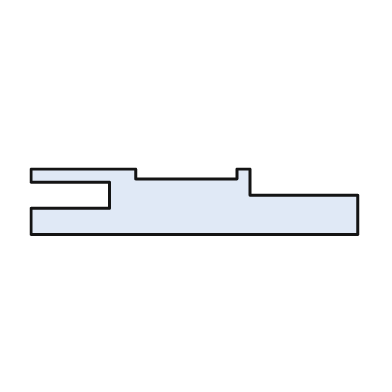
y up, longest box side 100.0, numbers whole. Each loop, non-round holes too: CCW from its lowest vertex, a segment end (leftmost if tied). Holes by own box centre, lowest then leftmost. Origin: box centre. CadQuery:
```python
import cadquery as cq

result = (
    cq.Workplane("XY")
    .moveTo(-50.0, -10.0)
    .lineTo(50.0, -10.0)
    .lineTo(50.0, 2.0)
    .lineTo(17.0, 2.0)
    .lineTo(17.0, 10.0)
    .lineTo(13.0, 10.0)
    .lineTo(13.0, 7.0)
    .lineTo(-18.0, 7.0)
    .lineTo(-18.0, 10.0)
    .lineTo(-50.0, 10.0)
    .lineTo(-50.0, 6.0)
    .lineTo(-26.0, 6.0)
    .lineTo(-26.0, -2.0)
    .lineTo(-50.0, -2.0)
    .close()
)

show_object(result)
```